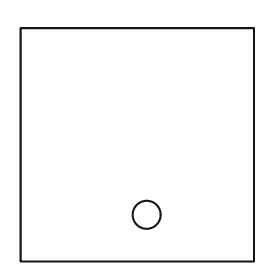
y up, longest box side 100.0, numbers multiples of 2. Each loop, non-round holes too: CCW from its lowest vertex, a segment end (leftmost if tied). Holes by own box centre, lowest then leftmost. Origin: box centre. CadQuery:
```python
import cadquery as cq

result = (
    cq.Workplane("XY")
    .moveTo(-50.0, -50.0)
    .lineTo(50.0, -50.0)
    .lineTo(50.0, 50.0)
    .lineTo(-50.0, 50.0)
    .close()
    .moveTo(4.0, -30.0)
    .circle(6.0)
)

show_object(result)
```